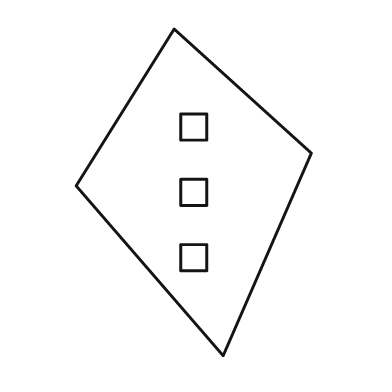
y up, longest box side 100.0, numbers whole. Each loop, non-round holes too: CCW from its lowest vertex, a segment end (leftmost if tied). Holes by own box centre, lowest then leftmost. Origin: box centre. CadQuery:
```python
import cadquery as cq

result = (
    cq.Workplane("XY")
    .moveTo(9.0, -50.0)
    .lineTo(36.0, 12.0)
    .lineTo(-6.0, 50.0)
    .lineTo(-36.0, 2.0)
    .close()
    .moveTo(-4.0, -24.0)
    .lineTo(4.0, -24.0)
    .lineTo(4.0, -16.0)
    .lineTo(-4.0, -16.0)
    .close()
    .moveTo(-4.0, -4.0)
    .lineTo(4.0, -4.0)
    .lineTo(4.0, 4.0)
    .lineTo(-4.0, 4.0)
    .close()
    .moveTo(-4.0, 16.0)
    .lineTo(4.0, 16.0)
    .lineTo(4.0, 24.0)
    .lineTo(-4.0, 24.0)
    .close()
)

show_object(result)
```